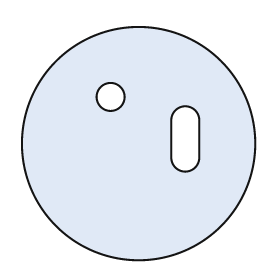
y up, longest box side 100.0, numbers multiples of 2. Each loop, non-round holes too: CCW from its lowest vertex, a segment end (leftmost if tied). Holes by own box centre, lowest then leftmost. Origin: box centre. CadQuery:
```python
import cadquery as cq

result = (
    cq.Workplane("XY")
    .moveTo(0.0, 0.0)
    .circle(50.0)
    .moveTo(14.0, -6.0)
    .threePointArc((20.0, -12.0), (26.0, -6.0))
    .lineTo(26.0, 10.0)
    .threePointArc((20.0, 16.0), (14.0, 10.0))
    .close()
    .moveTo(-12.0, 20.0)
    .circle(6.0)
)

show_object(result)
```